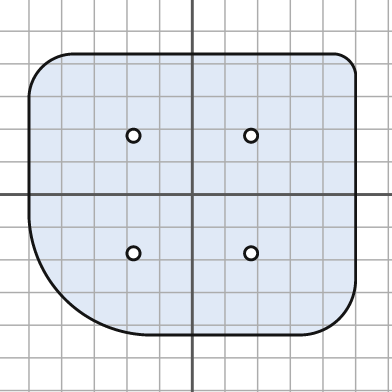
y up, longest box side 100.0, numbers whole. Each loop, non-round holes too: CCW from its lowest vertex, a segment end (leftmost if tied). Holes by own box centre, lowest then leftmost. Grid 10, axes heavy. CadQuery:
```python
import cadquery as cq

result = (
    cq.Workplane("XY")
    .moveTo(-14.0, -43.0)
    .lineTo(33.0, -43.0)
    .threePointArc((45.0, -38.0), (50.0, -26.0))
    .lineTo(50.0, 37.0)
    .threePointArc((48.0, 41.0), (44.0, 43.0))
    .lineTo(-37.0, 43.0)
    .threePointArc((-46.0, 39.0), (-50.0, 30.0))
    .lineTo(-50.0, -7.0)
    .threePointArc((-39.0, -32.0), (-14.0, -43.0))
    .close()
    .moveTo(-18.0, -18.0)
    .circle(2.0)
    .moveTo(18.0, -18.0)
    .circle(2.0)
    .moveTo(-18.0, 18.0)
    .circle(2.0)
    .moveTo(18.0, 18.0)
    .circle(2.0)
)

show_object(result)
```